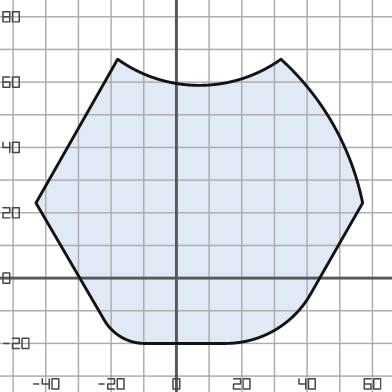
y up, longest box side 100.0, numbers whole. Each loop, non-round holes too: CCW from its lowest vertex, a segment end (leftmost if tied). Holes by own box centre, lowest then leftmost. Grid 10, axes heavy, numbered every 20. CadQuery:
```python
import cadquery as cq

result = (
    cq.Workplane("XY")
    .moveTo(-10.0, -20.0)
    .lineTo(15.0, -20.0)
    .threePointArc((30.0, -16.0), (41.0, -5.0))
    .lineTo(57.0, 23.0)
    .threePointArc((48.0, 47.0), (32.0, 67.0))
    .threePointArc((7.0, 59.0), (-18.0, 67.0))
    .lineTo(-43.0, 23.0)
    .lineTo(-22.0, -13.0)
    .threePointArc((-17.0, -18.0), (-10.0, -20.0))
    .close()
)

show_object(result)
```